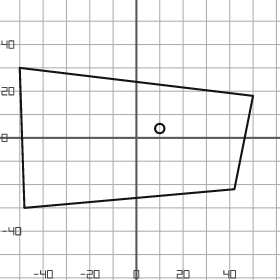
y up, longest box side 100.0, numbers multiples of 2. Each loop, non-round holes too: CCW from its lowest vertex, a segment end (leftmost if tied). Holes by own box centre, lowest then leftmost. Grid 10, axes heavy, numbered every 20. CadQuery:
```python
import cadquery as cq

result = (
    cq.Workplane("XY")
    .moveTo(-48.0, -30.0)
    .lineTo(42.0, -22.0)
    .lineTo(50.0, 18.0)
    .lineTo(-50.0, 30.0)
    .close()
    .moveTo(10.0, 4.0)
    .circle(2.0)
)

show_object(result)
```